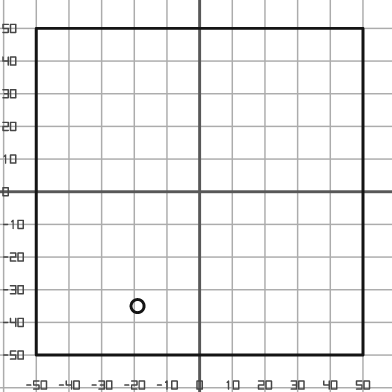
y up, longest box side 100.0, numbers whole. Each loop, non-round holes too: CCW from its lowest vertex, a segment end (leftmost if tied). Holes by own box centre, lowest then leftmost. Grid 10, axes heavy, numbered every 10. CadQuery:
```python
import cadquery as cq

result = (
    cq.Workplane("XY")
    .moveTo(-50.0, -50.0)
    .lineTo(50.0, -50.0)
    .lineTo(50.0, 50.0)
    .lineTo(-50.0, 50.0)
    .close()
    .moveTo(-19.0, -35.0)
    .circle(2.0)
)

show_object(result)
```